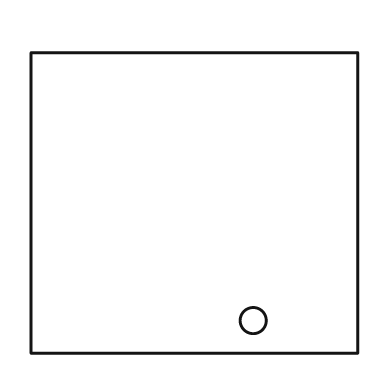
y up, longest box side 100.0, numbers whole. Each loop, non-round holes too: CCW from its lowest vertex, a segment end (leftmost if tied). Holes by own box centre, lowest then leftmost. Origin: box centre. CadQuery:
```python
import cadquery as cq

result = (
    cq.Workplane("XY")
    .moveTo(-50.0, -46.0)
    .lineTo(50.0, -46.0)
    .lineTo(50.0, 46.0)
    .lineTo(-50.0, 46.0)
    .close()
    .moveTo(18.0, -36.0)
    .circle(4.0)
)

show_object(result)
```